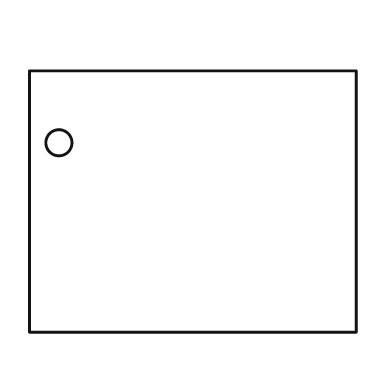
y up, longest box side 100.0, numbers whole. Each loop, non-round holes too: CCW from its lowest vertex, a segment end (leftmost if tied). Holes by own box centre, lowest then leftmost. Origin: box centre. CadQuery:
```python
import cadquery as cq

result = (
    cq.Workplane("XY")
    .moveTo(-50.0, -40.0)
    .lineTo(50.0, -40.0)
    .lineTo(50.0, 40.0)
    .lineTo(-50.0, 40.0)
    .close()
    .moveTo(-41.0, 18.0)
    .circle(4.0)
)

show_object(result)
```